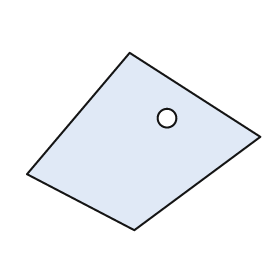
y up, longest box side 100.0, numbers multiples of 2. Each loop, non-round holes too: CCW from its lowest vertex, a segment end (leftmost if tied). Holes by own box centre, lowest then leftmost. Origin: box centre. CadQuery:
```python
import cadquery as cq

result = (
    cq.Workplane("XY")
    .moveTo(-4.0, -38.0)
    .lineTo(50.0, 2.0)
    .lineTo(-6.0, 38.0)
    .lineTo(-50.0, -14.0)
    .close()
    .moveTo(10.0, 10.0)
    .circle(4.0)
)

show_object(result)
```